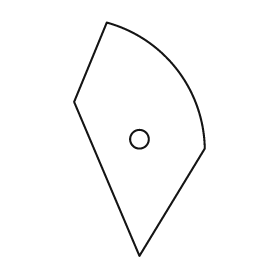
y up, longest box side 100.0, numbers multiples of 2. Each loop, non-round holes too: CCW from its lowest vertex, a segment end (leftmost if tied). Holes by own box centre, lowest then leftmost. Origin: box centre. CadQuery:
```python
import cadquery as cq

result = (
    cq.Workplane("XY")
    .moveTo(0.0, -50.0)
    .lineTo(28.0, -4.0)
    .threePointArc((16.0, 30.0), (-14.0, 50.0))
    .lineTo(-28.0, 16.0)
    .close()
    .moveTo(0.0, 0.0)
    .circle(4.0)
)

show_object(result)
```